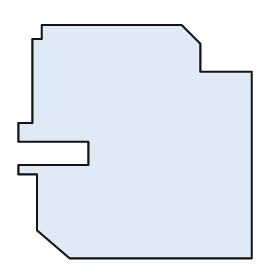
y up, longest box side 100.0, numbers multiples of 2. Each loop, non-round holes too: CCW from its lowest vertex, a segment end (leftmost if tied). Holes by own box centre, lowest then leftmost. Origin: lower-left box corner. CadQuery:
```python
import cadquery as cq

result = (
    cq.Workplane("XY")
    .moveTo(22.0, 0.0)
    .lineTo(100.0, 0.0)
    .lineTo(100.0, 80.0)
    .lineTo(78.0, 80.0)
    .lineTo(78.0, 92.0)
    .lineTo(70.0, 100.0)
    .lineTo(10.0, 100.0)
    .lineTo(10.0, 94.0)
    .lineTo(6.0, 94.0)
    .lineTo(6.0, 58.0)
    .lineTo(0.0, 58.0)
    .lineTo(0.0, 50.0)
    .lineTo(30.0, 50.0)
    .lineTo(30.0, 40.0)
    .lineTo(0.0, 40.0)
    .lineTo(0.0, 36.0)
    .lineTo(8.0, 36.0)
    .lineTo(8.0, 12.0)
    .close()
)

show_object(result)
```